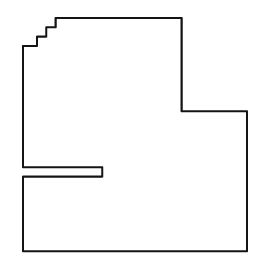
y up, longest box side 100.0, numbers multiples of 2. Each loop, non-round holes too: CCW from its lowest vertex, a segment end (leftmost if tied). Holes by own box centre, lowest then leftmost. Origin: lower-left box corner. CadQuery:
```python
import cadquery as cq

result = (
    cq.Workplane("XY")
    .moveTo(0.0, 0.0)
    .lineTo(96.0, 0.0)
    .lineTo(96.0, 60.0)
    .lineTo(68.0, 60.0)
    .lineTo(68.0, 100.0)
    .lineTo(14.0, 100.0)
    .lineTo(14.0, 96.0)
    .lineTo(10.0, 96.0)
    .lineTo(10.0, 92.0)
    .lineTo(6.0, 92.0)
    .lineTo(6.0, 88.0)
    .lineTo(0.0, 88.0)
    .lineTo(0.0, 36.0)
    .lineTo(34.0, 36.0)
    .lineTo(34.0, 32.0)
    .lineTo(0.0, 32.0)
    .close()
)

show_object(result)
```